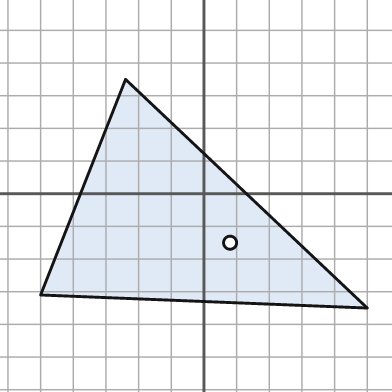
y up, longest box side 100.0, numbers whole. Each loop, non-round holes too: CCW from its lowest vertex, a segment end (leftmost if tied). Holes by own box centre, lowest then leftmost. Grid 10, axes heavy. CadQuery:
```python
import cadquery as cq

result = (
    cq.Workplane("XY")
    .moveTo(50.0, -35.0)
    .lineTo(-24.0, 35.0)
    .lineTo(-50.0, -31.0)
    .close()
    .moveTo(8.0, -15.0)
    .circle(2.0)
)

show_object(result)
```